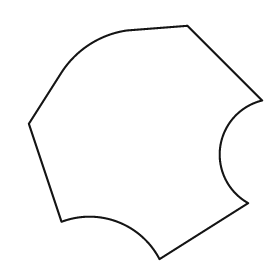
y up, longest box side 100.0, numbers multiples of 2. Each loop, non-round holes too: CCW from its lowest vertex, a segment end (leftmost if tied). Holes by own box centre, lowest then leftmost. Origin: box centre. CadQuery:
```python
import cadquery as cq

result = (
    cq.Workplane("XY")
    .moveTo(6.0, -50.0)
    .lineTo(44.0, -26.0)
    .threePointArc((32.0, -2.0), (50.0, 18.0))
    .lineTo(18.0, 50.0)
    .lineTo(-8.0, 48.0)
    .threePointArc((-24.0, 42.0), (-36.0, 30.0))
    .lineTo(-50.0, 8.0)
    .lineTo(-36.0, -34.0)
    .threePointArc((-12.0, -34.0), (6.0, -50.0))
    .close()
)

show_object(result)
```